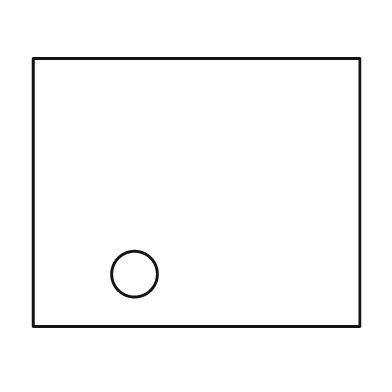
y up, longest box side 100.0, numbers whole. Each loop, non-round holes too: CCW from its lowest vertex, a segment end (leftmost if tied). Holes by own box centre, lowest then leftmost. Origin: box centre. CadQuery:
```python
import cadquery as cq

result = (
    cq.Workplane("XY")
    .moveTo(-50.0, -41.0)
    .lineTo(50.0, -41.0)
    .lineTo(50.0, 41.0)
    .lineTo(-50.0, 41.0)
    .close()
    .moveTo(-19.0, -25.0)
    .circle(7.0)
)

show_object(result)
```